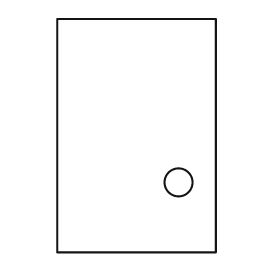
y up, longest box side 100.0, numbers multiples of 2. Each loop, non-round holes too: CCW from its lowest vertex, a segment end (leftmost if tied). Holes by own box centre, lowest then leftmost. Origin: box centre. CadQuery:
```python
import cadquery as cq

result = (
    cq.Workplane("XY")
    .moveTo(-34.0, -50.0)
    .lineTo(34.0, -50.0)
    .lineTo(34.0, 50.0)
    .lineTo(-34.0, 50.0)
    .close()
    .moveTo(18.0, -20.0)
    .circle(6.0)
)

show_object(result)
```